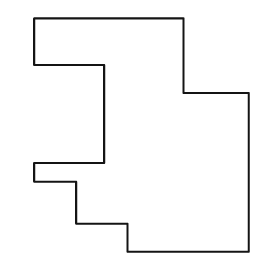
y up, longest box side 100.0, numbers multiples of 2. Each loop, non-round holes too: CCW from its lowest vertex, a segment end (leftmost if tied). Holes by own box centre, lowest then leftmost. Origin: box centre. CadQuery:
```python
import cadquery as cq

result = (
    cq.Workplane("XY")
    .moveTo(-6.0, -50.0)
    .lineTo(46.0, -50.0)
    .lineTo(46.0, 18.0)
    .lineTo(18.0, 18.0)
    .lineTo(18.0, 50.0)
    .lineTo(-46.0, 50.0)
    .lineTo(-46.0, 30.0)
    .lineTo(-16.0, 30.0)
    .lineTo(-16.0, -12.0)
    .lineTo(-46.0, -12.0)
    .lineTo(-46.0, -20.0)
    .lineTo(-28.0, -20.0)
    .lineTo(-28.0, -38.0)
    .lineTo(-6.0, -38.0)
    .close()
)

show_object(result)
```